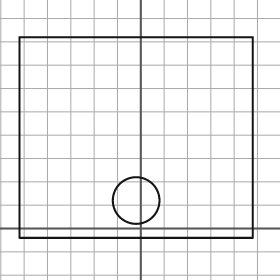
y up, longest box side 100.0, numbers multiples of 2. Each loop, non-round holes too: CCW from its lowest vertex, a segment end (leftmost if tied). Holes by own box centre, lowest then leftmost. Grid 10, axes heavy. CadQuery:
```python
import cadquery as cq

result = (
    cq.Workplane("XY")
    .moveTo(-52.0, -4.0)
    .lineTo(48.0, -4.0)
    .lineTo(48.0, 82.0)
    .lineTo(-52.0, 82.0)
    .close()
    .moveTo(-2.0, 12.0)
    .circle(10.0)
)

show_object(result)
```